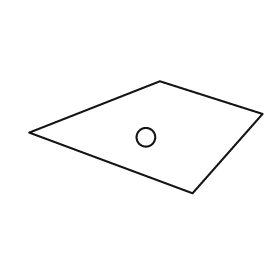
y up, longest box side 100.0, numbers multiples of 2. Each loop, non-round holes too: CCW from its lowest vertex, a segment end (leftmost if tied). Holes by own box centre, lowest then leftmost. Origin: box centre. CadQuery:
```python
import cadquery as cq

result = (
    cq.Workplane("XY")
    .moveTo(20.0, -24.0)
    .lineTo(50.0, 10.0)
    .lineTo(6.0, 24.0)
    .lineTo(-50.0, 2.0)
    .close()
    .moveTo(0.0, 0.0)
    .circle(4.0)
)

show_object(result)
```